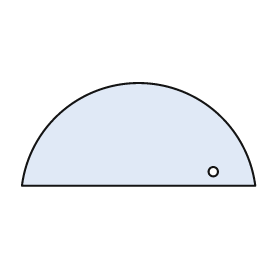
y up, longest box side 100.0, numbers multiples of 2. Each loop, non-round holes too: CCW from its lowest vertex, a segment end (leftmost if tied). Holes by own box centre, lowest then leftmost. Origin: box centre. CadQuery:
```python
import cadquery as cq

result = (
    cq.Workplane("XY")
    .moveTo(-50.0, -22.0)
    .lineTo(50.0, -22.0)
    .threePointArc((0.0, 22.0), (-50.0, -22.0))
    .close()
    .moveTo(32.0, -16.0)
    .circle(2.0)
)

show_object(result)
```